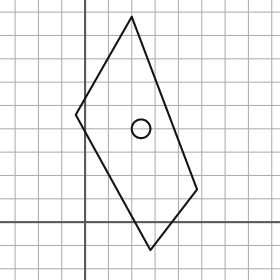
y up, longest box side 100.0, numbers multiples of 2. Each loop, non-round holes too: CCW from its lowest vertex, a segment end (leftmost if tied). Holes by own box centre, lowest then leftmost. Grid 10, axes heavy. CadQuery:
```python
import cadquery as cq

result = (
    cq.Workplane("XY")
    .moveTo(28.0, -12.0)
    .lineTo(48.0, 14.0)
    .lineTo(20.0, 88.0)
    .lineTo(-4.0, 46.0)
    .close()
    .moveTo(24.0, 40.0)
    .circle(4.0)
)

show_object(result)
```